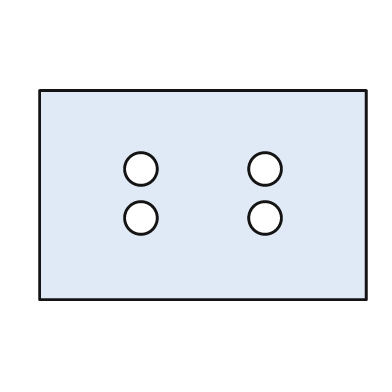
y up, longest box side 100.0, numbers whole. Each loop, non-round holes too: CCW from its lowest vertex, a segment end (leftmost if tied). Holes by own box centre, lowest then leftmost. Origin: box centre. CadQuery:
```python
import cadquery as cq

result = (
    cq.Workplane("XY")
    .moveTo(-50.0, -32.0)
    .lineTo(50.0, -32.0)
    .lineTo(50.0, 32.0)
    .lineTo(-50.0, 32.0)
    .close()
    .moveTo(-19.0, -7.0)
    .circle(5.0)
    .moveTo(19.0, -7.0)
    .circle(5.0)
    .moveTo(-19.0, 8.0)
    .circle(5.0)
    .moveTo(19.0, 8.0)
    .circle(5.0)
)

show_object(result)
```